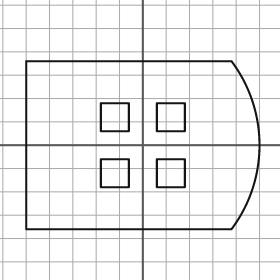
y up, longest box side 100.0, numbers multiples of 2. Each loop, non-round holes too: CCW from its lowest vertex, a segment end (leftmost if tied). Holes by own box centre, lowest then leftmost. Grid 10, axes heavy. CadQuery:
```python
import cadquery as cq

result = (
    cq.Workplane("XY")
    .moveTo(-50.0, -36.0)
    .lineTo(38.0, -36.0)
    .threePointArc((50.0, 0.0), (38.0, 36.0))
    .lineTo(-50.0, 36.0)
    .close()
    .moveTo(-18.0, -18.0)
    .lineTo(-6.0, -18.0)
    .lineTo(-6.0, -6.0)
    .lineTo(-18.0, -6.0)
    .close()
    .moveTo(6.0, -18.0)
    .lineTo(18.0, -18.0)
    .lineTo(18.0, -6.0)
    .lineTo(6.0, -6.0)
    .close()
    .moveTo(-18.0, 6.0)
    .lineTo(-6.0, 6.0)
    .lineTo(-6.0, 18.0)
    .lineTo(-18.0, 18.0)
    .close()
    .moveTo(6.0, 6.0)
    .lineTo(18.0, 6.0)
    .lineTo(18.0, 18.0)
    .lineTo(6.0, 18.0)
    .close()
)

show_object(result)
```